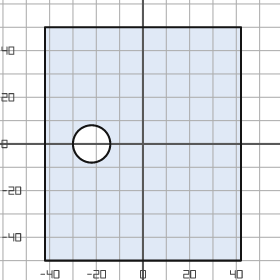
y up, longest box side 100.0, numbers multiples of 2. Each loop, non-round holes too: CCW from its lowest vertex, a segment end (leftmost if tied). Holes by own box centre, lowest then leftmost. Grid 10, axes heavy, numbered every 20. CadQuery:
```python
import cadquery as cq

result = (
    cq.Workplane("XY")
    .moveTo(-42.0, -50.0)
    .lineTo(42.0, -50.0)
    .lineTo(42.0, 50.0)
    .lineTo(-42.0, 50.0)
    .close()
    .moveTo(-22.0, 0.0)
    .circle(8.0)
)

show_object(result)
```